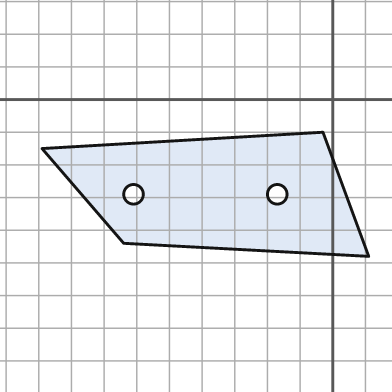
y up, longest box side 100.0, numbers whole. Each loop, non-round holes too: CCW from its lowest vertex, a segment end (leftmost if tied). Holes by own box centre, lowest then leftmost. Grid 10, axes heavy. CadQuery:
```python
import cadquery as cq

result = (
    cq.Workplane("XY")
    .moveTo(11.0, -48.0)
    .lineTo(-3.0, -10.0)
    .lineTo(-89.0, -15.0)
    .lineTo(-64.0, -44.0)
    .close()
    .moveTo(-61.0, -29.0)
    .circle(3.0)
    .moveTo(-17.0, -29.0)
    .circle(3.0)
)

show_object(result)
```